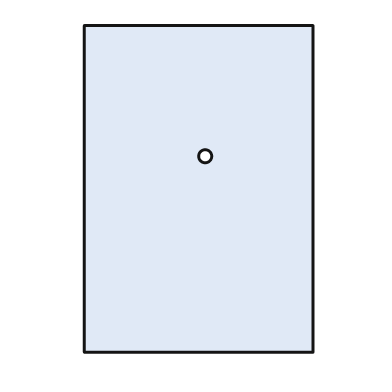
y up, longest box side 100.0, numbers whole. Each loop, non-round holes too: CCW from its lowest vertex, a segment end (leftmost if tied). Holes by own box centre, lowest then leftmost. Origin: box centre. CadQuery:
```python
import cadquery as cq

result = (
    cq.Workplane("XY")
    .moveTo(-35.0, -50.0)
    .lineTo(35.0, -50.0)
    .lineTo(35.0, 50.0)
    .lineTo(-35.0, 50.0)
    .close()
    .moveTo(2.0, 10.0)
    .circle(2.0)
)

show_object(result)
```